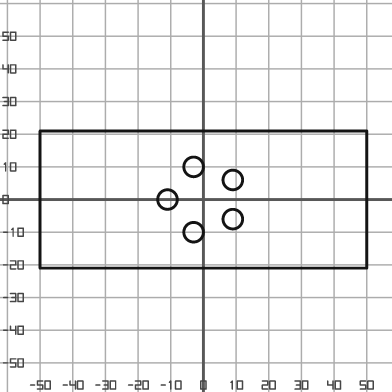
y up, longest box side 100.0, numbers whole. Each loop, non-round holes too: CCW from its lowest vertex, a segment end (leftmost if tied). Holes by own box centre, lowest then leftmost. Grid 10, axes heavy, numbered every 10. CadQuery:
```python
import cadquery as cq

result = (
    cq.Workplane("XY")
    .moveTo(-50.0, -21.0)
    .lineTo(50.0, -21.0)
    .lineTo(50.0, 21.0)
    .lineTo(-50.0, 21.0)
    .close()
    .moveTo(-3.0, -10.0)
    .circle(3.0)
    .moveTo(9.0, -6.0)
    .circle(3.0)
    .moveTo(-11.0, 0.0)
    .circle(3.0)
    .moveTo(9.0, 6.0)
    .circle(3.0)
    .moveTo(-3.0, 10.0)
    .circle(3.0)
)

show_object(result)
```